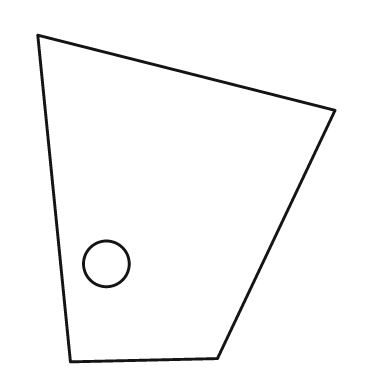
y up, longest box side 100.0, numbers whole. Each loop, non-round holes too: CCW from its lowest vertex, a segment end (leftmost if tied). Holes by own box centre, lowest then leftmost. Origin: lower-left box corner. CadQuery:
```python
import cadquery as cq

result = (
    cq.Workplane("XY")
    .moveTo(10.0, 0.0)
    .lineTo(55.0, 1.0)
    .lineTo(91.0, 77.0)
    .lineTo(0.0, 100.0)
    .close()
    .moveTo(21.0, 30.0)
    .circle(7.0)
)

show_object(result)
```